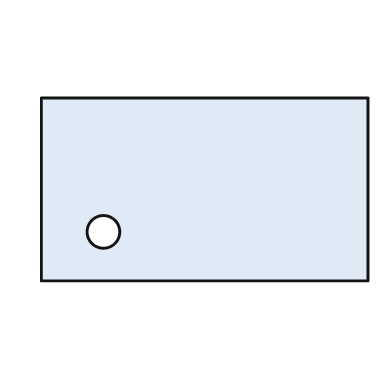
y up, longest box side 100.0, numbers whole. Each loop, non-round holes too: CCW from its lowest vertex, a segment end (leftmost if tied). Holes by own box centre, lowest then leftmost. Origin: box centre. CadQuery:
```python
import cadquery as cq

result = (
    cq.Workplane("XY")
    .moveTo(-50.0, -28.0)
    .lineTo(50.0, -28.0)
    .lineTo(50.0, 28.0)
    .lineTo(-50.0, 28.0)
    .close()
    .moveTo(-31.0, -13.0)
    .circle(5.0)
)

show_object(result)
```